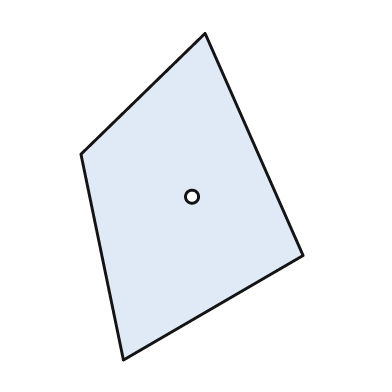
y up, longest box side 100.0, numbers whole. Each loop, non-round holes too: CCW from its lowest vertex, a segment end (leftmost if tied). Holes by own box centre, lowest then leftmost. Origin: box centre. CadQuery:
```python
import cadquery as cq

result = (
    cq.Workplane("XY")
    .moveTo(-21.0, -50.0)
    .lineTo(34.0, -18.0)
    .lineTo(4.0, 50.0)
    .lineTo(-34.0, 13.0)
    .close()
    .moveTo(0.0, 0.0)
    .circle(2.0)
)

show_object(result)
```